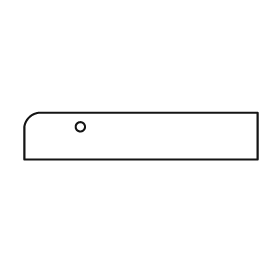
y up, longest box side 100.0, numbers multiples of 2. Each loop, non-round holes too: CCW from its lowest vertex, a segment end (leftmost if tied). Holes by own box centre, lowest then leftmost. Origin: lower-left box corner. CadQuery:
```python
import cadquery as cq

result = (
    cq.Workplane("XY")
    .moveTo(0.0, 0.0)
    .lineTo(100.0, 0.0)
    .lineTo(100.0, 20.0)
    .lineTo(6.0, 20.0)
    .threePointArc((2.0, 18.0), (0.0, 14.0))
    .close()
    .moveTo(24.0, 14.0)
    .circle(2.0)
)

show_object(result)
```